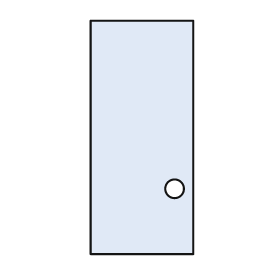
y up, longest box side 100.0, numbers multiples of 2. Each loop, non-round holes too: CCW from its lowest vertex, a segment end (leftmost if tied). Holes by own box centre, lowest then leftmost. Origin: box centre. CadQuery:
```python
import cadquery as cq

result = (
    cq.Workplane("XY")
    .moveTo(-22.0, -50.0)
    .lineTo(22.0, -50.0)
    .lineTo(22.0, 50.0)
    .lineTo(-22.0, 50.0)
    .close()
    .moveTo(14.0, -22.0)
    .circle(4.0)
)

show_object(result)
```